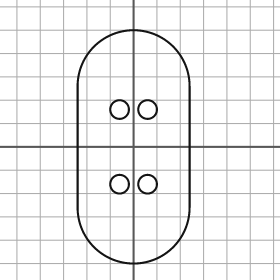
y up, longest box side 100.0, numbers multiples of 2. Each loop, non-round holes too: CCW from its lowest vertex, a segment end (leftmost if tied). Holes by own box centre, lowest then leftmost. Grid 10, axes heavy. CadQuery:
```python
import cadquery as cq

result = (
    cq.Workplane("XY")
    .moveTo(-24.0, -26.0)
    .threePointArc((0.0, -50.0), (24.0, -26.0))
    .lineTo(24.0, 26.0)
    .threePointArc((0.0, 50.0), (-24.0, 26.0))
    .close()
    .moveTo(-6.0, -16.0)
    .circle(4.0)
    .moveTo(6.0, -16.0)
    .circle(4.0)
    .moveTo(-6.0, 16.0)
    .circle(4.0)
    .moveTo(6.0, 16.0)
    .circle(4.0)
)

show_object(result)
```